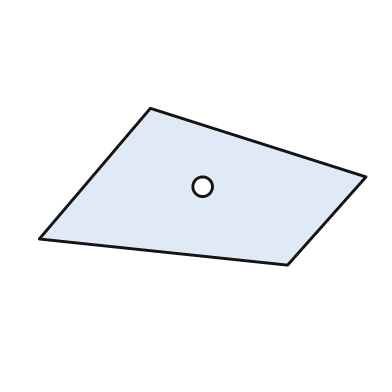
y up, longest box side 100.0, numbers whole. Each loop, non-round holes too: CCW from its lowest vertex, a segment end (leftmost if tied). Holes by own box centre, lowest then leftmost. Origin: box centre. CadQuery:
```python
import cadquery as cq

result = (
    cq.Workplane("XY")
    .moveTo(26.0, -24.0)
    .lineTo(50.0, 3.0)
    .lineTo(-16.0, 24.0)
    .lineTo(-50.0, -16.0)
    .close()
    .moveTo(0.0, 0.0)
    .circle(3.0)
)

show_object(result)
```